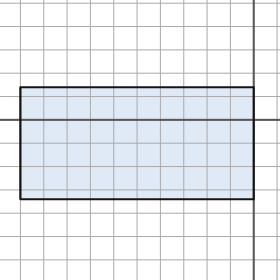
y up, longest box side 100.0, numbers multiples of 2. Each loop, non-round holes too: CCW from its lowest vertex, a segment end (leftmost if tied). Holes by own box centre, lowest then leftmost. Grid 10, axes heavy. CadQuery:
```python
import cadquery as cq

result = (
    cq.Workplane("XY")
    .moveTo(-100.0, -34.0)
    .lineTo(0.0, -34.0)
    .lineTo(0.0, 14.0)
    .lineTo(-100.0, 14.0)
    .close()
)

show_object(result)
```